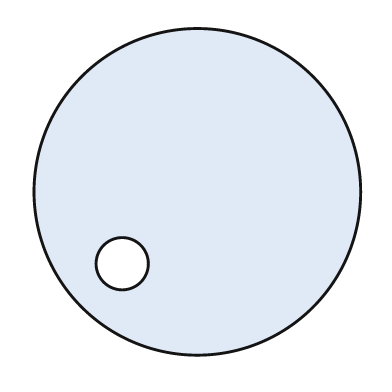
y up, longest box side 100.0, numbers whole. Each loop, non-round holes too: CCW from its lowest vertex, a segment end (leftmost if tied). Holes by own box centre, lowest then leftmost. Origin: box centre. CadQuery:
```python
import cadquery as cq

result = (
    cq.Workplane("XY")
    .moveTo(0.0, 0.0)
    .circle(50.0)
    .moveTo(-23.0, -22.0)
    .circle(8.0)
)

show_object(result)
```